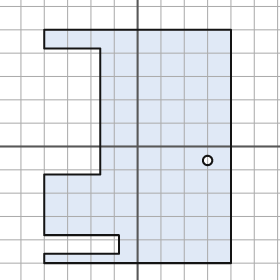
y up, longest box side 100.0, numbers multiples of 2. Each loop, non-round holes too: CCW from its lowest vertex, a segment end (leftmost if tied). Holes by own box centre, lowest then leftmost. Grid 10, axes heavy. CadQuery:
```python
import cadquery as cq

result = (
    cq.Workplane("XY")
    .moveTo(-40.0, -50.0)
    .lineTo(40.0, -50.0)
    .lineTo(40.0, 50.0)
    .lineTo(-40.0, 50.0)
    .lineTo(-40.0, 42.0)
    .lineTo(-16.0, 42.0)
    .lineTo(-16.0, -12.0)
    .lineTo(-40.0, -12.0)
    .lineTo(-40.0, -38.0)
    .lineTo(-8.0, -38.0)
    .lineTo(-8.0, -46.0)
    .lineTo(-40.0, -46.0)
    .close()
    .moveTo(30.0, -6.0)
    .circle(2.0)
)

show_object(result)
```